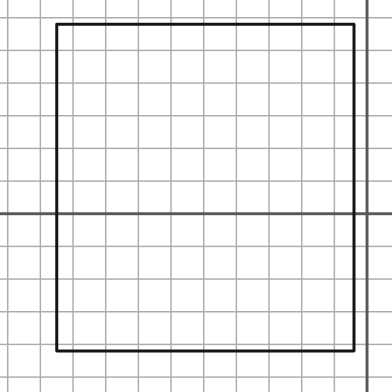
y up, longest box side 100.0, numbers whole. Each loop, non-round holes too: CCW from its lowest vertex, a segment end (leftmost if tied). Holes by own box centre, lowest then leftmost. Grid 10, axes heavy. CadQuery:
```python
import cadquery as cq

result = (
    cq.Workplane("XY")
    .moveTo(-95.0, -42.0)
    .lineTo(-4.0, -42.0)
    .lineTo(-4.0, 58.0)
    .lineTo(-95.0, 58.0)
    .close()
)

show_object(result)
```